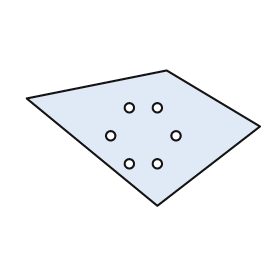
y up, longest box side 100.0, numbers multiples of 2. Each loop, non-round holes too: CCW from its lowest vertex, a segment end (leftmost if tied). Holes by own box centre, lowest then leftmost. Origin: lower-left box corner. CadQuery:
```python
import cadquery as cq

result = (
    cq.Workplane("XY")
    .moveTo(56.0, 0.0)
    .lineTo(100.0, 34.0)
    .lineTo(60.0, 58.0)
    .lineTo(0.0, 46.0)
    .close()
    .moveTo(44.0, 18.0)
    .circle(2.0)
    .moveTo(56.0, 18.0)
    .circle(2.0)
    .moveTo(36.0, 30.0)
    .circle(2.0)
    .moveTo(64.0, 30.0)
    .circle(2.0)
    .moveTo(44.0, 42.0)
    .circle(2.0)
    .moveTo(56.0, 42.0)
    .circle(2.0)
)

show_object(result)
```